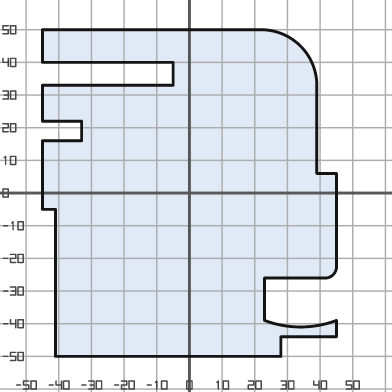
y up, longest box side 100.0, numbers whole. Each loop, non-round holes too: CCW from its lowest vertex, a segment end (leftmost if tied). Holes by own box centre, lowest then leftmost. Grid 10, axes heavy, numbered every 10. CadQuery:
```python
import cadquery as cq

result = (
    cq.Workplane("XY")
    .moveTo(-41.0, -50.0)
    .lineTo(28.0, -50.0)
    .lineTo(28.0, -44.0)
    .lineTo(45.0, -44.0)
    .lineTo(45.0, -39.0)
    .threePointArc((34.0, -41.0), (23.0, -39.0))
    .lineTo(23.0, -26.0)
    .lineTo(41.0, -26.0)
    .threePointArc((44.0, -25.0), (45.0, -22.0))
    .lineTo(45.0, 6.0)
    .lineTo(39.0, 6.0)
    .lineTo(39.0, 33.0)
    .threePointArc((34.0, 45.0), (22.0, 50.0))
    .lineTo(-45.0, 50.0)
    .lineTo(-45.0, 40.0)
    .lineTo(-5.0, 40.0)
    .lineTo(-5.0, 33.0)
    .lineTo(-45.0, 33.0)
    .lineTo(-45.0, 22.0)
    .lineTo(-33.0, 22.0)
    .lineTo(-33.0, 16.0)
    .lineTo(-45.0, 16.0)
    .lineTo(-45.0, -5.0)
    .lineTo(-41.0, -5.0)
    .close()
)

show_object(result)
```